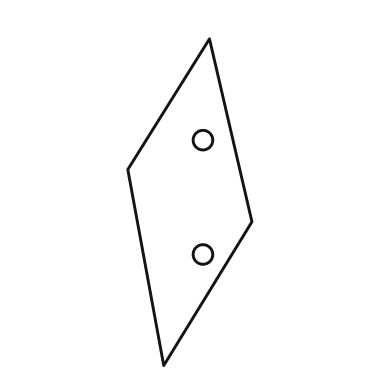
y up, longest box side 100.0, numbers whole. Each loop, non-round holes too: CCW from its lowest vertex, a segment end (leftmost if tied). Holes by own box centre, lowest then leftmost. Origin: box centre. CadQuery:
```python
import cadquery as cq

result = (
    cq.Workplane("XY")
    .moveTo(-8.0, -50.0)
    .lineTo(19.0, -6.0)
    .lineTo(6.0, 50.0)
    .lineTo(-19.0, 10.0)
    .close()
    .moveTo(4.0, -16.0)
    .circle(3.0)
    .moveTo(4.0, 19.0)
    .circle(3.0)
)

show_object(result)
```